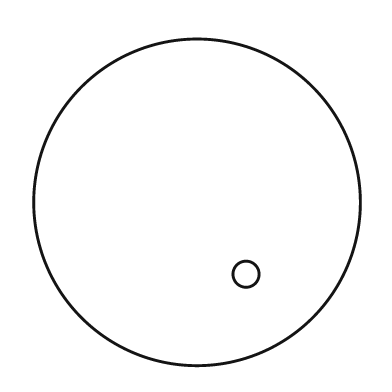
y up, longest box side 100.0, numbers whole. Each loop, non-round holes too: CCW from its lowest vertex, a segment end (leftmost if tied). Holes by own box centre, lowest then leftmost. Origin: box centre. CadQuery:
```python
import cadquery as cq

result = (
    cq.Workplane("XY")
    .moveTo(0.0, 0.0)
    .circle(50.0)
    .moveTo(15.0, -22.0)
    .circle(4.0)
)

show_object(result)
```